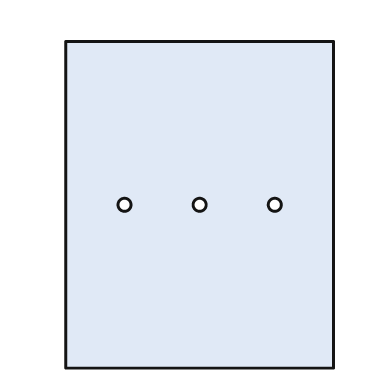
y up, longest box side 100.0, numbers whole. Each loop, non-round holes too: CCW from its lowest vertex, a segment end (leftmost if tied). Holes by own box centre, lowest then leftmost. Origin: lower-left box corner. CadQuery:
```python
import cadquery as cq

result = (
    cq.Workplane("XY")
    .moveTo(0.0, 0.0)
    .lineTo(82.0, 0.0)
    .lineTo(82.0, 100.0)
    .lineTo(0.0, 100.0)
    .close()
    .moveTo(18.0, 50.0)
    .circle(2.0)
    .moveTo(41.0, 50.0)
    .circle(2.0)
    .moveTo(64.0, 50.0)
    .circle(2.0)
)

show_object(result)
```